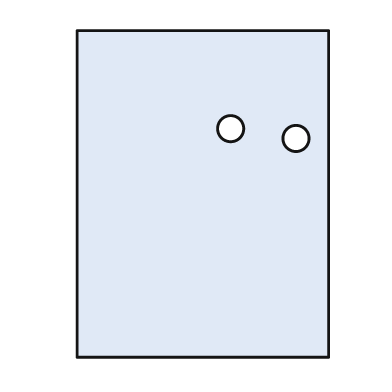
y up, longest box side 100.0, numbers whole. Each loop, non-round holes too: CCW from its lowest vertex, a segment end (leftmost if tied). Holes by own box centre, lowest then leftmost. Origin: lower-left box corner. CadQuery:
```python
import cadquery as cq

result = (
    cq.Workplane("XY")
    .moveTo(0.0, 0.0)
    .lineTo(77.0, 0.0)
    .lineTo(77.0, 100.0)
    .lineTo(0.0, 100.0)
    .close()
    .moveTo(67.0, 67.0)
    .circle(4.0)
    .moveTo(47.0, 70.0)
    .circle(4.0)
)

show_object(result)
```